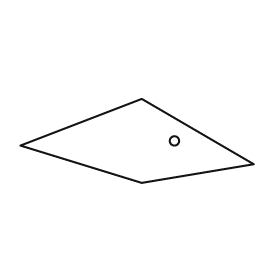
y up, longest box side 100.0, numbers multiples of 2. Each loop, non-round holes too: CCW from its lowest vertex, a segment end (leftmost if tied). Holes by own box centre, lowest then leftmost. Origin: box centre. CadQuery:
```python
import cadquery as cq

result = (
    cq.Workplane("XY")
    .moveTo(2.0, -18.0)
    .lineTo(50.0, -10.0)
    .lineTo(2.0, 18.0)
    .lineTo(-50.0, -2.0)
    .close()
    .moveTo(16.0, 0.0)
    .circle(2.0)
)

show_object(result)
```